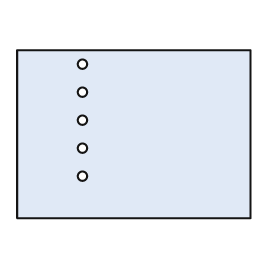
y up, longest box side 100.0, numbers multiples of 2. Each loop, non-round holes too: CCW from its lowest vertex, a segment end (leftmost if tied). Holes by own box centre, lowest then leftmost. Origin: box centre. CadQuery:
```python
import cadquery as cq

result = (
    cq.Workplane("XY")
    .moveTo(-50.0, -36.0)
    .lineTo(50.0, -36.0)
    .lineTo(50.0, 36.0)
    .lineTo(-50.0, 36.0)
    .close()
    .moveTo(-22.0, -18.0)
    .circle(2.0)
    .moveTo(-22.0, -6.0)
    .circle(2.0)
    .moveTo(-22.0, 6.0)
    .circle(2.0)
    .moveTo(-22.0, 18.0)
    .circle(2.0)
    .moveTo(-22.0, 30.0)
    .circle(2.0)
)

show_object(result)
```